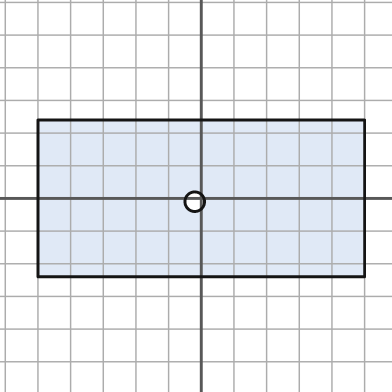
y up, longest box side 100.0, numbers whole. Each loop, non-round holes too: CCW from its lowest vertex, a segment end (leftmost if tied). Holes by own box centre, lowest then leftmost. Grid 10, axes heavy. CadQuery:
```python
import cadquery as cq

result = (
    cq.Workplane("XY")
    .moveTo(-50.0, -24.0)
    .lineTo(50.0, -24.0)
    .lineTo(50.0, 24.0)
    .lineTo(-50.0, 24.0)
    .close()
    .moveTo(-2.0, -1.0)
    .circle(3.0)
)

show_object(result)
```